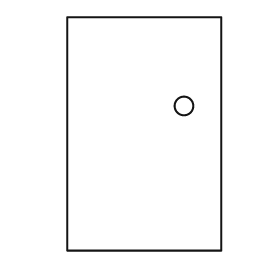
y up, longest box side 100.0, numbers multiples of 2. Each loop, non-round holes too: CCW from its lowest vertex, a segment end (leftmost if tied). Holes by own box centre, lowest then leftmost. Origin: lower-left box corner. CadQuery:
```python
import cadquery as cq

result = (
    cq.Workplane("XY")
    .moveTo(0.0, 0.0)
    .lineTo(66.0, 0.0)
    .lineTo(66.0, 100.0)
    .lineTo(0.0, 100.0)
    .close()
    .moveTo(50.0, 62.0)
    .circle(4.0)
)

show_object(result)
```